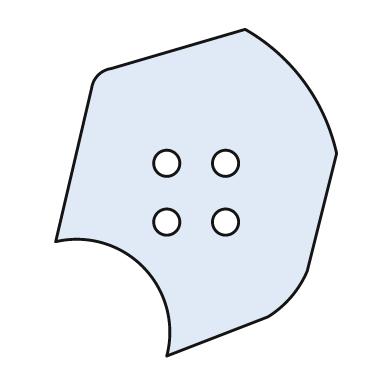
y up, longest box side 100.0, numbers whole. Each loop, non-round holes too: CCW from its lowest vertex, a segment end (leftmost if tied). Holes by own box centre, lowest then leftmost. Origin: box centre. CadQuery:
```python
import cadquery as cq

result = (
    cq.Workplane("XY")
    .moveTo(-9.0, -50.0)
    .lineTo(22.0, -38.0)
    .threePointArc((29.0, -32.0), (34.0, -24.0))
    .lineTo(43.0, 12.0)
    .threePointArc((33.0, 34.0), (15.0, 50.0))
    .lineTo(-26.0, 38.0)
    .threePointArc((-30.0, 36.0), (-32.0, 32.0))
    .lineTo(-43.0, -15.0)
    .threePointArc((-16.0, -23.0), (-9.0, -50.0))
    .close()
    .moveTo(-9.0, -9.0)
    .circle(4.0)
    .moveTo(9.0, -9.0)
    .circle(4.0)
    .moveTo(-9.0, 9.0)
    .circle(4.0)
    .moveTo(9.0, 9.0)
    .circle(4.0)
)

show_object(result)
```